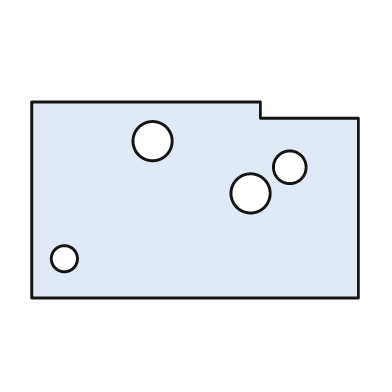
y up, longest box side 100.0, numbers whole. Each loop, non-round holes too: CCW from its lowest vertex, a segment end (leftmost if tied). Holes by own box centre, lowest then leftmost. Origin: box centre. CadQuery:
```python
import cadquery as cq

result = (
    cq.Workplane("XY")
    .moveTo(-50.0, -30.0)
    .lineTo(50.0, -30.0)
    .lineTo(50.0, 25.0)
    .lineTo(20.0, 25.0)
    .lineTo(20.0, 30.0)
    .lineTo(-50.0, 30.0)
    .close()
    .moveTo(-40.0, -18.0)
    .circle(4.0)
    .moveTo(17.0, 2.0)
    .circle(6.0)
    .moveTo(29.0, 10.0)
    .circle(5.0)
    .moveTo(-13.0, 18.0)
    .circle(6.0)
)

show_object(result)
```